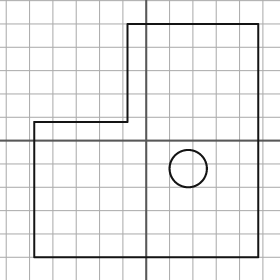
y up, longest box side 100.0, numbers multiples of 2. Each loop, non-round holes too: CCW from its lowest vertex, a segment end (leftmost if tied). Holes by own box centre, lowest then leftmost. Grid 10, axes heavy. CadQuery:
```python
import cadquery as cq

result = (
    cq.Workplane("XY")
    .moveTo(-48.0, -50.0)
    .lineTo(48.0, -50.0)
    .lineTo(48.0, 50.0)
    .lineTo(-8.0, 50.0)
    .lineTo(-8.0, 8.0)
    .lineTo(-48.0, 8.0)
    .close()
    .moveTo(18.0, -12.0)
    .circle(8.0)
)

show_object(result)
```